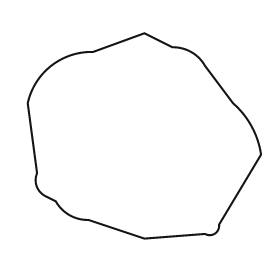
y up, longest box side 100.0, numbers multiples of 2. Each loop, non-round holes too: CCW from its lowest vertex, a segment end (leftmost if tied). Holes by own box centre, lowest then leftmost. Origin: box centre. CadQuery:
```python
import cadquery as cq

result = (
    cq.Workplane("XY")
    .moveTo(0.0, -44.0)
    .lineTo(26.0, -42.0)
    .threePointArc((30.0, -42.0), (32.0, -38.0))
    .lineTo(50.0, -8.0)
    .threePointArc((46.0, 4.0), (38.0, 14.0))
    .lineTo(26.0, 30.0)
    .threePointArc((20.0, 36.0), (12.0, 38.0))
    .lineTo(0.0, 44.0)
    .lineTo(-22.0, 36.0)
    .threePointArc((-40.0, 30.0), (-50.0, 14.0))
    .lineTo(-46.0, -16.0)
    .threePointArc((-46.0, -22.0), (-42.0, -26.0))
    .lineTo(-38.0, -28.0)
    .threePointArc((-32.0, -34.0), (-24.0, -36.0))
    .close()
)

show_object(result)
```